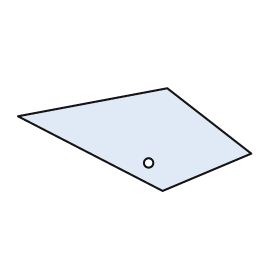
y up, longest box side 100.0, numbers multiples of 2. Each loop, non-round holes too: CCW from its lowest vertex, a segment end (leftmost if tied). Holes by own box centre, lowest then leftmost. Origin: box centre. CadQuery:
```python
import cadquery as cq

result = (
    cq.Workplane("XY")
    .moveTo(12.0, -22.0)
    .lineTo(50.0, -6.0)
    .lineTo(14.0, 22.0)
    .lineTo(-50.0, 10.0)
    .close()
    .moveTo(6.0, -10.0)
    .circle(2.0)
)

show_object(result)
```